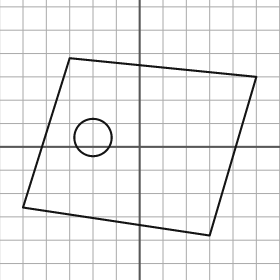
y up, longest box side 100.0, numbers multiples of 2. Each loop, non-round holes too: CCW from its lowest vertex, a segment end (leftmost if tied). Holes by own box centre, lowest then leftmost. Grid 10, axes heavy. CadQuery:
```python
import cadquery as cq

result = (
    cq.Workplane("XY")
    .moveTo(30.0, -38.0)
    .lineTo(50.0, 30.0)
    .lineTo(-30.0, 38.0)
    .lineTo(-50.0, -26.0)
    .close()
    .moveTo(-20.0, 4.0)
    .circle(8.0)
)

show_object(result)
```